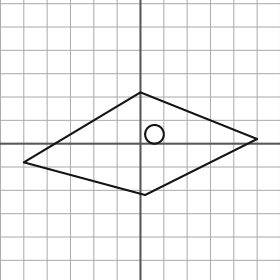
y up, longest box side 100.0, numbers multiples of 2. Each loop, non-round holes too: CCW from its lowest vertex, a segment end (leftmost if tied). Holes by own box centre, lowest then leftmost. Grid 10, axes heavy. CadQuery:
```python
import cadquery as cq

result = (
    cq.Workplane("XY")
    .moveTo(2.0, -22.0)
    .lineTo(50.0, 2.0)
    .lineTo(0.0, 22.0)
    .lineTo(-50.0, -8.0)
    .close()
    .moveTo(6.0, 4.0)
    .circle(4.0)
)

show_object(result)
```